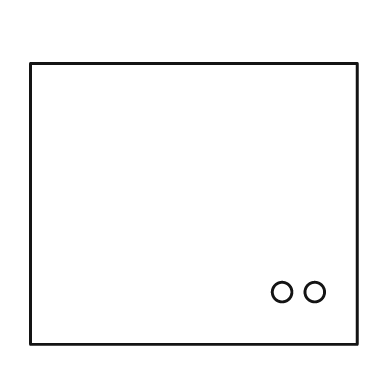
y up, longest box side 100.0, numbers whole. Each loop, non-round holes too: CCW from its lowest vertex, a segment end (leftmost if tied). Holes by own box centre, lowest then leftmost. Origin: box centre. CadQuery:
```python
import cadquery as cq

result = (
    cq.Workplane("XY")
    .moveTo(-50.0, -43.0)
    .lineTo(50.0, -43.0)
    .lineTo(50.0, 43.0)
    .lineTo(-50.0, 43.0)
    .close()
    .moveTo(27.0, -27.0)
    .circle(3.0)
    .moveTo(37.0, -27.0)
    .circle(3.0)
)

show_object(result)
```